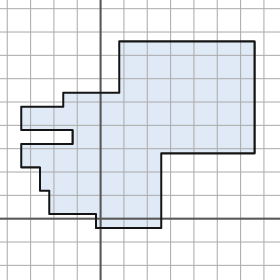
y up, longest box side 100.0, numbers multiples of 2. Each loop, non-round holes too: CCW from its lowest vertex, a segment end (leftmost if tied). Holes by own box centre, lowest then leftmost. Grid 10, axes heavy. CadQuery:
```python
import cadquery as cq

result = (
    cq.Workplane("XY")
    .moveTo(-2.0, -4.0)
    .lineTo(26.0, -4.0)
    .lineTo(26.0, 28.0)
    .lineTo(66.0, 28.0)
    .lineTo(66.0, 76.0)
    .lineTo(8.0, 76.0)
    .lineTo(8.0, 54.0)
    .lineTo(-16.0, 54.0)
    .lineTo(-16.0, 48.0)
    .lineTo(-34.0, 48.0)
    .lineTo(-34.0, 38.0)
    .lineTo(-12.0, 38.0)
    .lineTo(-12.0, 32.0)
    .lineTo(-34.0, 32.0)
    .lineTo(-34.0, 22.0)
    .lineTo(-26.0, 22.0)
    .lineTo(-26.0, 12.0)
    .lineTo(-22.0, 12.0)
    .lineTo(-22.0, 2.0)
    .lineTo(-2.0, 2.0)
    .close()
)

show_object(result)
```